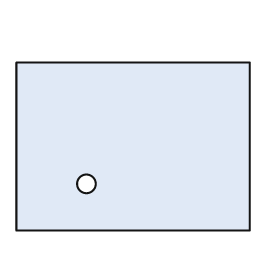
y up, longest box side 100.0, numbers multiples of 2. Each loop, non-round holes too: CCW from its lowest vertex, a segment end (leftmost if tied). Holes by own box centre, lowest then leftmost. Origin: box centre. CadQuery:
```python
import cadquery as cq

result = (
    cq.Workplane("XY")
    .moveTo(-50.0, -36.0)
    .lineTo(50.0, -36.0)
    .lineTo(50.0, 36.0)
    .lineTo(-50.0, 36.0)
    .close()
    .moveTo(-20.0, -16.0)
    .circle(4.0)
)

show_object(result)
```